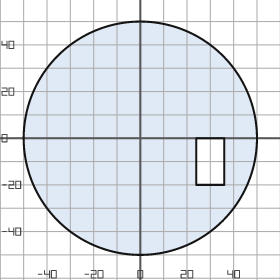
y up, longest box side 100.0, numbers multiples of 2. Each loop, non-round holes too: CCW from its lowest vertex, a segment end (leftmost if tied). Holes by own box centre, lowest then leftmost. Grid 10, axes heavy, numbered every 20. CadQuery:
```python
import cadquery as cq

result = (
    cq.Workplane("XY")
    .moveTo(0.0, 0.0)
    .circle(50.0)
    .moveTo(24.0, -20.0)
    .lineTo(36.0, -20.0)
    .lineTo(36.0, 0.0)
    .lineTo(24.0, 0.0)
    .close()
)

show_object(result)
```